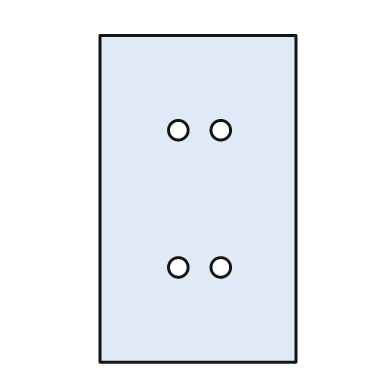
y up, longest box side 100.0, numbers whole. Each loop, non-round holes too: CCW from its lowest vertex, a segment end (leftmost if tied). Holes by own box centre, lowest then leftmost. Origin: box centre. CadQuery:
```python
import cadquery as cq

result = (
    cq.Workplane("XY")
    .moveTo(-30.0, -50.0)
    .lineTo(30.0, -50.0)
    .lineTo(30.0, 50.0)
    .lineTo(-30.0, 50.0)
    .close()
    .moveTo(-6.0, -21.0)
    .circle(3.0)
    .moveTo(7.0, -21.0)
    .circle(3.0)
    .moveTo(-6.0, 21.0)
    .circle(3.0)
    .moveTo(7.0, 21.0)
    .circle(3.0)
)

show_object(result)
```